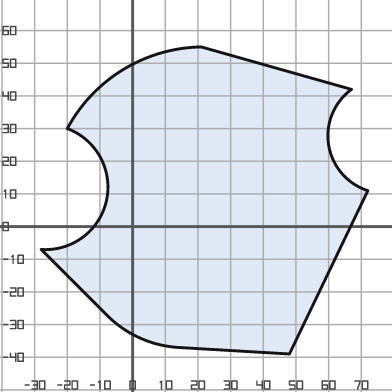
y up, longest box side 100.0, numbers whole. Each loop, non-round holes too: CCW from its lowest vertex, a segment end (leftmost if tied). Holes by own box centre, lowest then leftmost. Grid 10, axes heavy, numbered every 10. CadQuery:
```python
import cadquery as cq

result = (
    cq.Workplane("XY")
    .moveTo(48.0, -39.0)
    .lineTo(72.0, 11.0)
    .threePointArc((60.0, 25.0), (67.0, 42.0))
    .lineTo(21.0, 55.0)
    .threePointArc((-3.0, 48.0), (-20.0, 30.0))
    .threePointArc((-8.0, 8.0), (-28.0, -7.0))
    .lineTo(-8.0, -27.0)
    .threePointArc((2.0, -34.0), (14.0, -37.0))
    .close()
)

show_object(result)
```